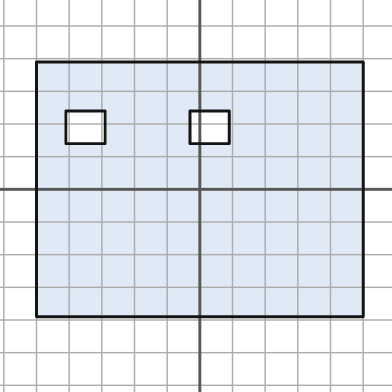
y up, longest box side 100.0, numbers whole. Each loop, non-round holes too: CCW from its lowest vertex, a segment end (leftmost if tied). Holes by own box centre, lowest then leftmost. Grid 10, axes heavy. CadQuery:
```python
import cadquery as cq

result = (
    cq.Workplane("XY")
    .moveTo(-50.0, -39.0)
    .lineTo(50.0, -39.0)
    .lineTo(50.0, 39.0)
    .lineTo(-50.0, 39.0)
    .close()
    .moveTo(-41.0, 14.0)
    .lineTo(-29.0, 14.0)
    .lineTo(-29.0, 24.0)
    .lineTo(-41.0, 24.0)
    .close()
    .moveTo(-3.0, 14.0)
    .lineTo(9.0, 14.0)
    .lineTo(9.0, 24.0)
    .lineTo(-3.0, 24.0)
    .close()
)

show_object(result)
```